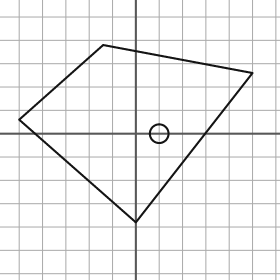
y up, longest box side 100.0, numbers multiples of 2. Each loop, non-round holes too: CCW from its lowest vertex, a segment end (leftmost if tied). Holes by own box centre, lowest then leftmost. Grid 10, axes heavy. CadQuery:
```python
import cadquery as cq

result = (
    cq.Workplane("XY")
    .moveTo(0.0, -38.0)
    .lineTo(50.0, 26.0)
    .lineTo(-14.0, 38.0)
    .lineTo(-50.0, 6.0)
    .close()
    .moveTo(10.0, 0.0)
    .circle(4.0)
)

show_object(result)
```